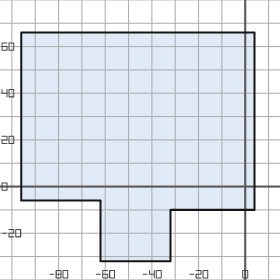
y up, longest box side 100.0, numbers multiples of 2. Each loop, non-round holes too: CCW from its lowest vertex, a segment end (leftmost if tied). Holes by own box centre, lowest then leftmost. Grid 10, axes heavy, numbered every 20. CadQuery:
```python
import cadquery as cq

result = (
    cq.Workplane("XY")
    .moveTo(-62.0, -32.0)
    .lineTo(-32.0, -32.0)
    .lineTo(-32.0, -10.0)
    .lineTo(4.0, -10.0)
    .lineTo(4.0, 66.0)
    .lineTo(-96.0, 66.0)
    .lineTo(-96.0, -6.0)
    .lineTo(-62.0, -6.0)
    .close()
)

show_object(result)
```